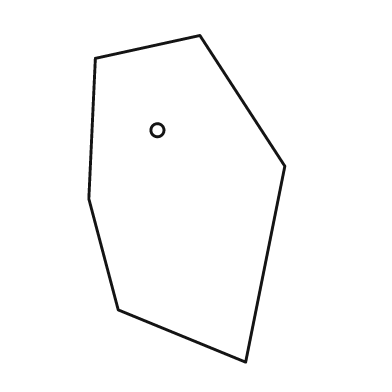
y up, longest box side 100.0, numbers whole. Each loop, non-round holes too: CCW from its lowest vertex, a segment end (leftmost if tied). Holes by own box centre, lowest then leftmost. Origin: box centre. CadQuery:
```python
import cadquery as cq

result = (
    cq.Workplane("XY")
    .moveTo(18.0, -50.0)
    .lineTo(30.0, 10.0)
    .lineTo(4.0, 50.0)
    .lineTo(-28.0, 43.0)
    .lineTo(-30.0, 0.0)
    .lineTo(-21.0, -34.0)
    .close()
    .moveTo(-9.0, 21.0)
    .circle(2.0)
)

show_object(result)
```